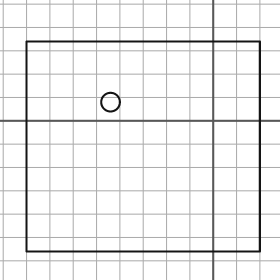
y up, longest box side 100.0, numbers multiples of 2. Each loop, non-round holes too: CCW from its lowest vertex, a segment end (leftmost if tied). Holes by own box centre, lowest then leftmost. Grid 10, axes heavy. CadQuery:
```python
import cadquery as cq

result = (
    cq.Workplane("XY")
    .moveTo(-80.0, -56.0)
    .lineTo(20.0, -56.0)
    .lineTo(20.0, 34.0)
    .lineTo(-80.0, 34.0)
    .close()
    .moveTo(-44.0, 8.0)
    .circle(4.0)
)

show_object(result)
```